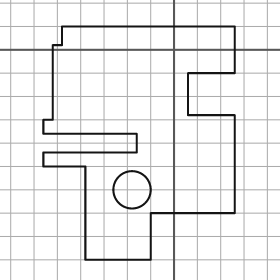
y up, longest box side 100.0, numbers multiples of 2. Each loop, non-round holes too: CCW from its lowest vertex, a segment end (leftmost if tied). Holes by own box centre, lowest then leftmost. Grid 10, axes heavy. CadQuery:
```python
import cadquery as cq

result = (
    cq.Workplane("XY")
    .moveTo(-38.0, -90.0)
    .lineTo(-10.0, -90.0)
    .lineTo(-10.0, -70.0)
    .lineTo(26.0, -70.0)
    .lineTo(26.0, -28.0)
    .lineTo(6.0, -28.0)
    .lineTo(6.0, -10.0)
    .lineTo(26.0, -10.0)
    .lineTo(26.0, 10.0)
    .lineTo(-48.0, 10.0)
    .lineTo(-48.0, 2.0)
    .lineTo(-52.0, 2.0)
    .lineTo(-52.0, -30.0)
    .lineTo(-56.0, -30.0)
    .lineTo(-56.0, -36.0)
    .lineTo(-16.0, -36.0)
    .lineTo(-16.0, -44.0)
    .lineTo(-56.0, -44.0)
    .lineTo(-56.0, -50.0)
    .lineTo(-38.0, -50.0)
    .close()
    .moveTo(-18.0, -60.0)
    .circle(8.0)
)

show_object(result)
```